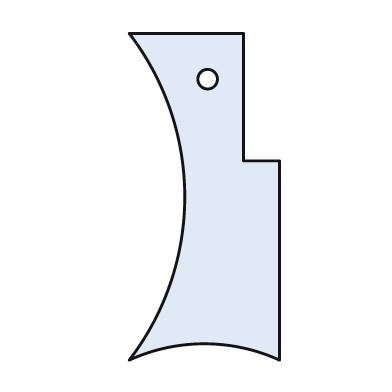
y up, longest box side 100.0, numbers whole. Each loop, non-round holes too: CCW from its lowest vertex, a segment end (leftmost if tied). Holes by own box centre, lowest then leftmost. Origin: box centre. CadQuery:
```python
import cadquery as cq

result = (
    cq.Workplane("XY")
    .moveTo(-23.0, -50.0)
    .threePointArc((0.0, -45.0), (23.0, -50.0))
    .lineTo(23.0, 11.0)
    .lineTo(12.0, 11.0)
    .lineTo(12.0, 50.0)
    .lineTo(-23.0, 50.0)
    .threePointArc((-6.0, 0.0), (-23.0, -50.0))
    .close()
    .moveTo(1.0, 36.0)
    .circle(3.0)
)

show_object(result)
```